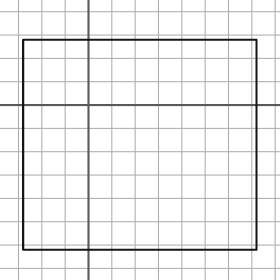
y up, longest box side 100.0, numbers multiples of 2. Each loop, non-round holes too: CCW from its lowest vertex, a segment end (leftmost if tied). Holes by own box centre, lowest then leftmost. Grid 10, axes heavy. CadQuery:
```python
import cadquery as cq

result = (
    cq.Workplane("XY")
    .moveTo(-28.0, -62.0)
    .lineTo(72.0, -62.0)
    .lineTo(72.0, 28.0)
    .lineTo(-28.0, 28.0)
    .close()
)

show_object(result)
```